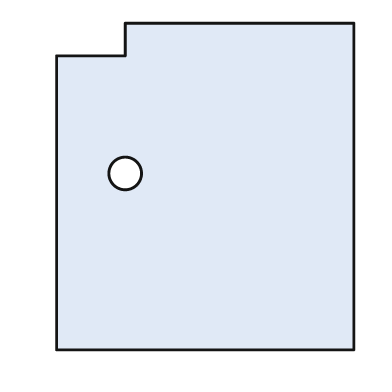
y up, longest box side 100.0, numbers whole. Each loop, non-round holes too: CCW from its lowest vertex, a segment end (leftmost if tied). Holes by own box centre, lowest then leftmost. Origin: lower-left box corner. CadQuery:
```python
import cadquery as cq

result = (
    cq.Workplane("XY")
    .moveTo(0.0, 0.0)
    .lineTo(91.0, 0.0)
    .lineTo(91.0, 100.0)
    .lineTo(21.0, 100.0)
    .lineTo(21.0, 90.0)
    .lineTo(0.0, 90.0)
    .close()
    .moveTo(21.0, 54.0)
    .circle(5.0)
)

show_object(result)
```